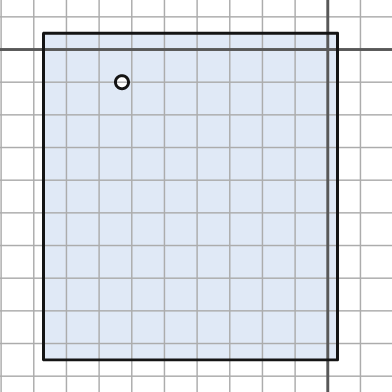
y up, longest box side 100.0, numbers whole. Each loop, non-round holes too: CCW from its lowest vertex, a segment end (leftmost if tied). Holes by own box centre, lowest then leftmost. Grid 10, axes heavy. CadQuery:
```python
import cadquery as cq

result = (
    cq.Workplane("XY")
    .moveTo(-87.0, -95.0)
    .lineTo(3.0, -95.0)
    .lineTo(3.0, 5.0)
    .lineTo(-87.0, 5.0)
    .close()
    .moveTo(-63.0, -10.0)
    .circle(2.0)
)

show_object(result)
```